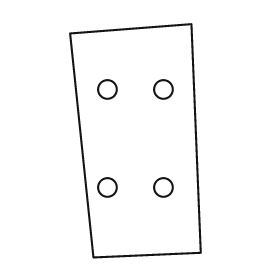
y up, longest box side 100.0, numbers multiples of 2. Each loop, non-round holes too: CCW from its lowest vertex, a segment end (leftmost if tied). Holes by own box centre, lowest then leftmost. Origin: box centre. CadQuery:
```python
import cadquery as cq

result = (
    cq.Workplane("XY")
    .moveTo(-18.0, -50.0)
    .lineTo(28.0, -48.0)
    .lineTo(24.0, 50.0)
    .lineTo(-28.0, 46.0)
    .close()
    .moveTo(-12.0, -20.0)
    .circle(4.0)
    .moveTo(12.0, -20.0)
    .circle(4.0)
    .moveTo(-12.0, 22.0)
    .circle(4.0)
    .moveTo(12.0, 22.0)
    .circle(4.0)
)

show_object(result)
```